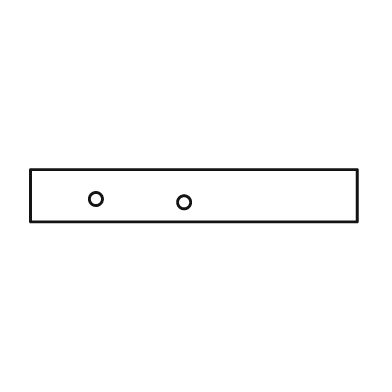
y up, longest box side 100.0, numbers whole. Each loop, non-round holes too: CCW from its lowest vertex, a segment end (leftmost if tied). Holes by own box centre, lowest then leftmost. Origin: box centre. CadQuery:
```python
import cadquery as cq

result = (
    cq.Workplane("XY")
    .moveTo(-50.0, -8.0)
    .lineTo(50.0, -8.0)
    .lineTo(50.0, 8.0)
    .lineTo(-50.0, 8.0)
    .close()
    .moveTo(-3.0, -2.0)
    .circle(2.0)
    .moveTo(-30.0, -1.0)
    .circle(2.0)
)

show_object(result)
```